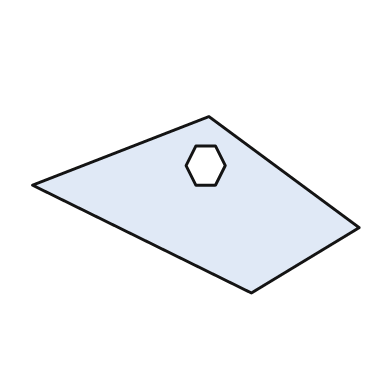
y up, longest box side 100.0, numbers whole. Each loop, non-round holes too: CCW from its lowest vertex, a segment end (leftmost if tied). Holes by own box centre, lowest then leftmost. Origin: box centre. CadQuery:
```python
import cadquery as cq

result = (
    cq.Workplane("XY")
    .moveTo(17.0, -27.0)
    .lineTo(50.0, -7.0)
    .lineTo(4.0, 27.0)
    .lineTo(-50.0, 6.0)
    .close()
    .moveTo(0.0, 6.0)
    .lineTo(6.0, 6.0)
    .lineTo(9.0, 12.0)
    .lineTo(6.0, 18.0)
    .lineTo(0.0, 18.0)
    .lineTo(-3.0, 12.0)
    .close()
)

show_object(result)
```